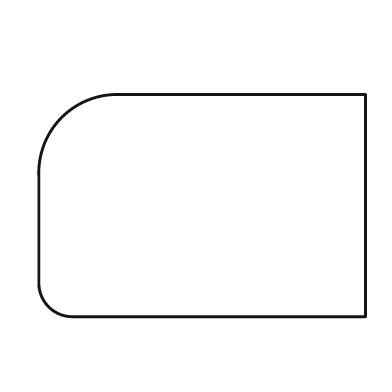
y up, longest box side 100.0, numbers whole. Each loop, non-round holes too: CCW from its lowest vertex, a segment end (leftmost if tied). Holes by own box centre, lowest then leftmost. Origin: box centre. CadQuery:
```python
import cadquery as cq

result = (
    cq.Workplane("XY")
    .moveTo(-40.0, -34.0)
    .lineTo(50.0, -34.0)
    .lineTo(50.0, 34.0)
    .lineTo(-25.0, 34.0)
    .threePointArc((-43.0, 27.0), (-50.0, 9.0))
    .lineTo(-50.0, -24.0)
    .threePointArc((-47.0, -31.0), (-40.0, -34.0))
    .close()
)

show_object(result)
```